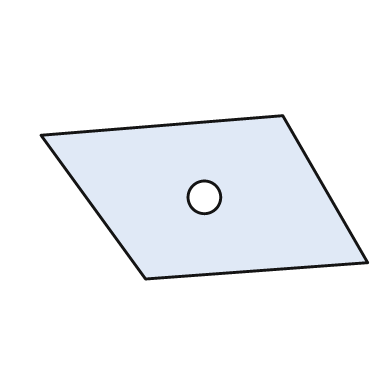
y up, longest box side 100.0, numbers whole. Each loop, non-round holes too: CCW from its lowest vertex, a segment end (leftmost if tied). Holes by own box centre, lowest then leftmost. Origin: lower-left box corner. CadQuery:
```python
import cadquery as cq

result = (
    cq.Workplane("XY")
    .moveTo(32.0, 0.0)
    .lineTo(100.0, 5.0)
    .lineTo(74.0, 50.0)
    .lineTo(0.0, 44.0)
    .close()
    .moveTo(50.0, 25.0)
    .circle(5.0)
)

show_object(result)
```